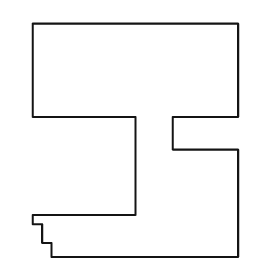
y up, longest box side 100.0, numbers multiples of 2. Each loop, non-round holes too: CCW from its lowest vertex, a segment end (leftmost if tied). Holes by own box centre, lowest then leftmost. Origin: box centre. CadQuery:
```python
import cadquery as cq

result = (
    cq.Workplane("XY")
    .moveTo(-36.0, -50.0)
    .lineTo(44.0, -50.0)
    .lineTo(44.0, -4.0)
    .lineTo(16.0, -4.0)
    .lineTo(16.0, 10.0)
    .lineTo(44.0, 10.0)
    .lineTo(44.0, 50.0)
    .lineTo(-44.0, 50.0)
    .lineTo(-44.0, 10.0)
    .lineTo(0.0, 10.0)
    .lineTo(0.0, -32.0)
    .lineTo(-44.0, -32.0)
    .lineTo(-44.0, -36.0)
    .lineTo(-40.0, -36.0)
    .lineTo(-40.0, -44.0)
    .lineTo(-36.0, -44.0)
    .close()
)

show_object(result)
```